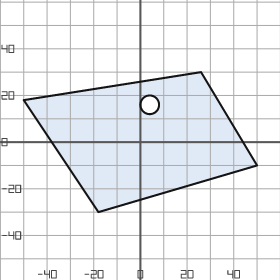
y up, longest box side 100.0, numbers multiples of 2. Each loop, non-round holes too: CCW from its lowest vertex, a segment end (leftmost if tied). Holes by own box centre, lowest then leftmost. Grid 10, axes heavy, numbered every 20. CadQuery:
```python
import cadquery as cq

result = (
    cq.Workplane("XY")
    .moveTo(-18.0, -30.0)
    .lineTo(50.0, -10.0)
    .lineTo(26.0, 30.0)
    .lineTo(-50.0, 18.0)
    .close()
    .moveTo(4.0, 16.0)
    .circle(4.0)
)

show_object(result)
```